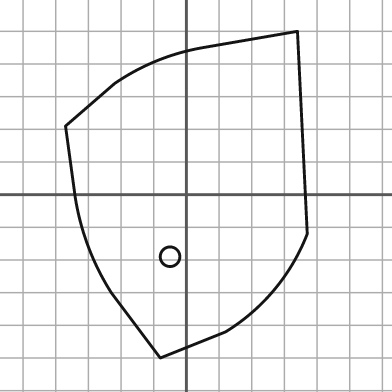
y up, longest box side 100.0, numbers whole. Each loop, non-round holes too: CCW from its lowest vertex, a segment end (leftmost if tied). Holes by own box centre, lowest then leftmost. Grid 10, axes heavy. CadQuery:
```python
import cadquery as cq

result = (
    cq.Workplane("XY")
    .moveTo(-8.0, -50.0)
    .lineTo(12.0, -42.0)
    .threePointArc((27.0, -29.0), (37.0, -12.0))
    .lineTo(34.0, 50.0)
    .lineTo(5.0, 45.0)
    .threePointArc((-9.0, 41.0), (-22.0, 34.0))
    .lineTo(-37.0, 21.0)
    .lineTo(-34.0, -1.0)
    .threePointArc((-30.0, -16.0), (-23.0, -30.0))
    .close()
    .moveTo(-5.0, -19.0)
    .circle(3.0)
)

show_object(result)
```